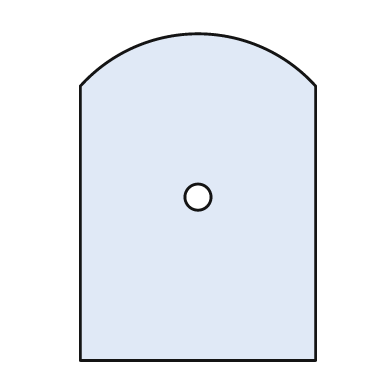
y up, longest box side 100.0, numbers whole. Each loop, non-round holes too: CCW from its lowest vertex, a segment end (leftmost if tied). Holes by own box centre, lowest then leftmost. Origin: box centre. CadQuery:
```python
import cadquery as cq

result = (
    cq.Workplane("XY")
    .moveTo(-36.0, -50.0)
    .lineTo(36.0, -50.0)
    .lineTo(36.0, 34.0)
    .threePointArc((0.0, 50.0), (-36.0, 34.0))
    .close()
    .moveTo(0.0, 0.0)
    .circle(4.0)
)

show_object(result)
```